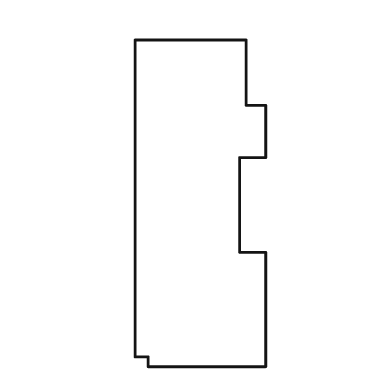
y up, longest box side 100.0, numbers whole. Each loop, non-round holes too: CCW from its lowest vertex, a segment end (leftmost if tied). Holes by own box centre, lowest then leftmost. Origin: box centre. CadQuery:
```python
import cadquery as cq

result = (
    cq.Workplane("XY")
    .moveTo(-16.0, -50.0)
    .lineTo(20.0, -50.0)
    .lineTo(20.0, -15.0)
    .lineTo(12.0, -15.0)
    .lineTo(12.0, 14.0)
    .lineTo(20.0, 14.0)
    .lineTo(20.0, 30.0)
    .lineTo(14.0, 30.0)
    .lineTo(14.0, 50.0)
    .lineTo(-20.0, 50.0)
    .lineTo(-20.0, -47.0)
    .lineTo(-16.0, -47.0)
    .close()
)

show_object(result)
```